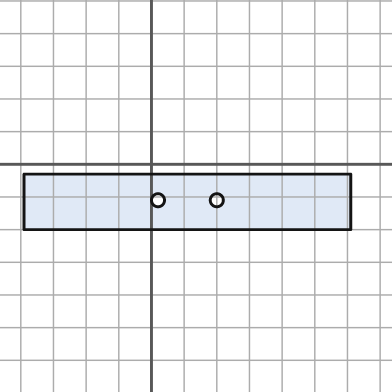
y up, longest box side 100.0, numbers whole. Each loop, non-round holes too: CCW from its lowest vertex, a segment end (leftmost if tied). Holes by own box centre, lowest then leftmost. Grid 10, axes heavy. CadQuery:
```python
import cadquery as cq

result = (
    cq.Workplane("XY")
    .moveTo(-39.0, -20.0)
    .lineTo(61.0, -20.0)
    .lineTo(61.0, -3.0)
    .lineTo(-39.0, -3.0)
    .close()
    .moveTo(2.0, -11.0)
    .circle(2.0)
    .moveTo(20.0, -11.0)
    .circle(2.0)
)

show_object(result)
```